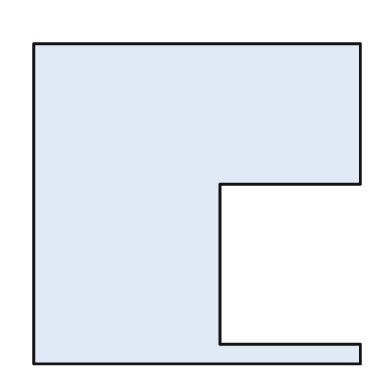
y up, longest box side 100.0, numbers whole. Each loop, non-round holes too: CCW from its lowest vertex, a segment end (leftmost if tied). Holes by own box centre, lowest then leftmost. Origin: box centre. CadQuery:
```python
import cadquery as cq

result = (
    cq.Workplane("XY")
    .moveTo(-50.0, -49.0)
    .lineTo(50.0, -49.0)
    .lineTo(50.0, -43.0)
    .lineTo(7.0, -43.0)
    .lineTo(7.0, 6.0)
    .lineTo(50.0, 6.0)
    .lineTo(50.0, 49.0)
    .lineTo(-50.0, 49.0)
    .close()
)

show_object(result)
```